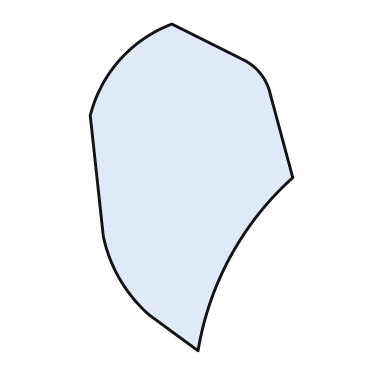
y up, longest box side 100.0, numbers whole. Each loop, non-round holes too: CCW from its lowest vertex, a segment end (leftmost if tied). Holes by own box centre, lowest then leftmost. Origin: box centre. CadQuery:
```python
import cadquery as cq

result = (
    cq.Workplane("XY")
    .moveTo(2.0, -50.0)
    .threePointArc((12.0, -21.0), (31.0, 3.0))
    .lineTo(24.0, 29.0)
    .threePointArc((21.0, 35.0), (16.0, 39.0))
    .lineTo(-6.0, 50.0)
    .threePointArc((-22.0, 39.0), (-31.0, 22.0))
    .lineTo(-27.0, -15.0)
    .threePointArc((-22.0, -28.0), (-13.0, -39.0))
    .close()
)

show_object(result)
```